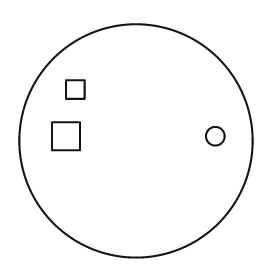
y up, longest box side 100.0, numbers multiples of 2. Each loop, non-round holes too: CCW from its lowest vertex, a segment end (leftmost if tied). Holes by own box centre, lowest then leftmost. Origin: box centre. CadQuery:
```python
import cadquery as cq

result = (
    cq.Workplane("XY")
    .moveTo(0.0, 0.0)
    .circle(50.0)
    .moveTo(-36.0, -4.0)
    .lineTo(-24.0, -4.0)
    .lineTo(-24.0, 8.0)
    .lineTo(-36.0, 8.0)
    .close()
    .moveTo(34.0, 2.0)
    .circle(4.0)
    .moveTo(-30.0, 18.0)
    .lineTo(-22.0, 18.0)
    .lineTo(-22.0, 26.0)
    .lineTo(-30.0, 26.0)
    .close()
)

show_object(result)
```